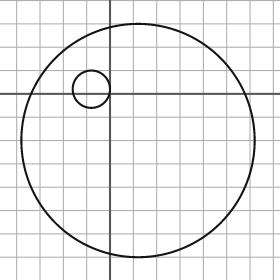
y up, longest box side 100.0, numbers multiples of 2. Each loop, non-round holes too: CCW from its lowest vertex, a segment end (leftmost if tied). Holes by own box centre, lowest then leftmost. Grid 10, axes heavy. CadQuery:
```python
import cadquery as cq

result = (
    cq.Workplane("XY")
    .moveTo(12.0, -20.0)
    .circle(50.0)
    .moveTo(-8.0, 2.0)
    .circle(8.0)
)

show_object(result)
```